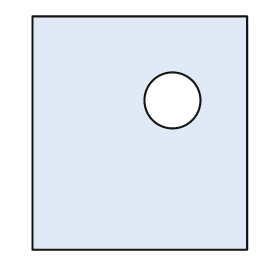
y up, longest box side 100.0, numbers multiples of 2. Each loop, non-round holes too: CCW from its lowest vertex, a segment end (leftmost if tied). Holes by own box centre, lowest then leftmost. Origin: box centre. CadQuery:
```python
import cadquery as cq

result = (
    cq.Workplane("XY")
    .moveTo(-46.0, -50.0)
    .lineTo(46.0, -50.0)
    .lineTo(46.0, 50.0)
    .lineTo(-46.0, 50.0)
    .close()
    .moveTo(14.0, 14.0)
    .circle(12.0)
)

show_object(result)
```